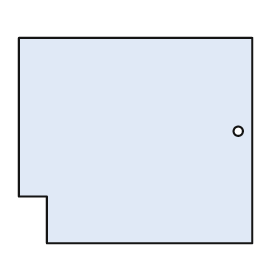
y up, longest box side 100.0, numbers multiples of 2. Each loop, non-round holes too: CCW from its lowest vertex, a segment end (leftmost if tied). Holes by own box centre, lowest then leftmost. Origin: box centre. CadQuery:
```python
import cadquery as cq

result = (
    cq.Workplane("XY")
    .moveTo(-38.0, -44.0)
    .lineTo(50.0, -44.0)
    .lineTo(50.0, 44.0)
    .lineTo(-50.0, 44.0)
    .lineTo(-50.0, -24.0)
    .lineTo(-38.0, -24.0)
    .close()
    .moveTo(44.0, 4.0)
    .circle(2.0)
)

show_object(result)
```